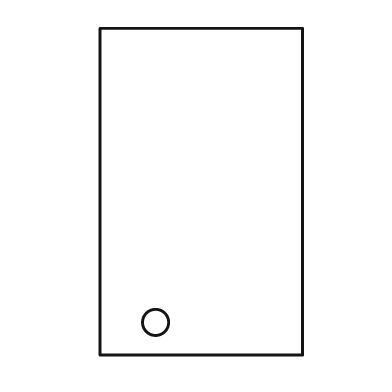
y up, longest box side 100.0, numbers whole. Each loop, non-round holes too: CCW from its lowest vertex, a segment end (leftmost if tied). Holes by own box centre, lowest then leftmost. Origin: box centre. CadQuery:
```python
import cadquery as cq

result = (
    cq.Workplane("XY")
    .moveTo(-31.0, -50.0)
    .lineTo(31.0, -50.0)
    .lineTo(31.0, 50.0)
    .lineTo(-31.0, 50.0)
    .close()
    .moveTo(-14.0, -40.0)
    .circle(4.0)
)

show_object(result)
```